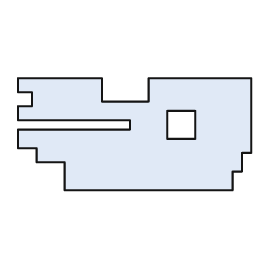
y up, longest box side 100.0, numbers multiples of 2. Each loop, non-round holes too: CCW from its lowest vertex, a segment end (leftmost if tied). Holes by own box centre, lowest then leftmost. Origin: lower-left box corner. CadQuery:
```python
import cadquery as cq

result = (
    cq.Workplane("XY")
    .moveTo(20.0, 0.0)
    .lineTo(92.0, 0.0)
    .lineTo(92.0, 8.0)
    .lineTo(96.0, 8.0)
    .lineTo(96.0, 16.0)
    .lineTo(100.0, 16.0)
    .lineTo(100.0, 48.0)
    .lineTo(56.0, 48.0)
    .lineTo(56.0, 38.0)
    .lineTo(36.0, 38.0)
    .lineTo(36.0, 48.0)
    .lineTo(0.0, 48.0)
    .lineTo(0.0, 42.0)
    .lineTo(6.0, 42.0)
    .lineTo(6.0, 36.0)
    .lineTo(0.0, 36.0)
    .lineTo(0.0, 30.0)
    .lineTo(48.0, 30.0)
    .lineTo(48.0, 26.0)
    .lineTo(0.0, 26.0)
    .lineTo(0.0, 18.0)
    .lineTo(8.0, 18.0)
    .lineTo(8.0, 12.0)
    .lineTo(20.0, 12.0)
    .close()
    .moveTo(64.0, 22.0)
    .lineTo(76.0, 22.0)
    .lineTo(76.0, 34.0)
    .lineTo(64.0, 34.0)
    .close()
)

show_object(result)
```